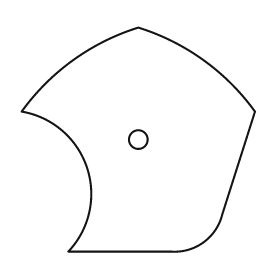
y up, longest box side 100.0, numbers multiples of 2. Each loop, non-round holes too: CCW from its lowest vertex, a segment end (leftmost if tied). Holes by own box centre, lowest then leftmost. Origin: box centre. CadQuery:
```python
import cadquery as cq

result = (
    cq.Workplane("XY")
    .moveTo(-30.0, -48.0)
    .lineTo(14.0, -48.0)
    .threePointArc((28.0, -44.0), (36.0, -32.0))
    .lineTo(50.0, 12.0)
    .threePointArc((28.0, 34.0), (0.0, 48.0))
    .threePointArc((-28.0, 34.0), (-50.0, 12.0))
    .threePointArc((-22.0, -12.0), (-30.0, -48.0))
    .close()
    .moveTo(0.0, 0.0)
    .circle(4.0)
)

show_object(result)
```